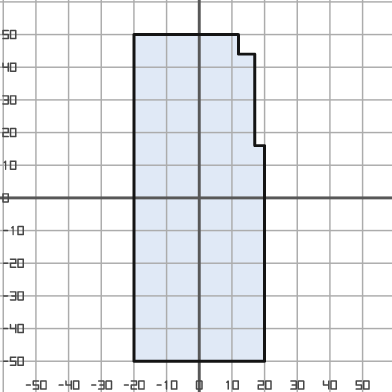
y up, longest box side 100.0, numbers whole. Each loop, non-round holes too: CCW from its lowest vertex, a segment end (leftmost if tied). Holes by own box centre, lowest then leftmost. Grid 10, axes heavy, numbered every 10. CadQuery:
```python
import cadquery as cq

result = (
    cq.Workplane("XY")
    .moveTo(-20.0, -50.0)
    .lineTo(20.0, -50.0)
    .lineTo(20.0, 16.0)
    .lineTo(17.0, 16.0)
    .lineTo(17.0, 44.0)
    .lineTo(12.0, 44.0)
    .lineTo(12.0, 50.0)
    .lineTo(-20.0, 50.0)
    .close()
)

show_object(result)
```